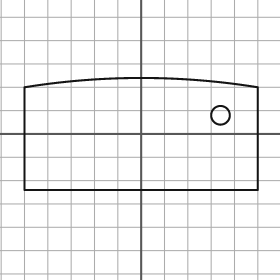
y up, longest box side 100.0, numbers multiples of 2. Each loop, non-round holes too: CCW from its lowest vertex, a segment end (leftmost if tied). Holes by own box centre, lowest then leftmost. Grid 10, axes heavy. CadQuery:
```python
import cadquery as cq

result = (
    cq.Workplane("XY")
    .moveTo(-50.0, -24.0)
    .lineTo(50.0, -24.0)
    .lineTo(50.0, 20.0)
    .threePointArc((0.0, 24.0), (-50.0, 20.0))
    .close()
    .moveTo(34.0, 8.0)
    .circle(4.0)
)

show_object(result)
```